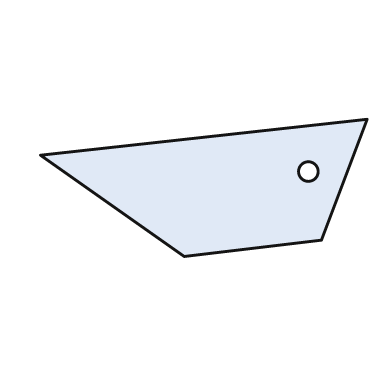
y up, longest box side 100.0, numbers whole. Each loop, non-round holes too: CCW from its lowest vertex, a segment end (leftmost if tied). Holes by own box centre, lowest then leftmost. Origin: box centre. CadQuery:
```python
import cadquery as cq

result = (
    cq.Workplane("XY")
    .moveTo(-6.0, -21.0)
    .lineTo(36.0, -16.0)
    .lineTo(50.0, 21.0)
    .lineTo(-50.0, 10.0)
    .close()
    .moveTo(32.0, 5.0)
    .circle(3.0)
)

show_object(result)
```